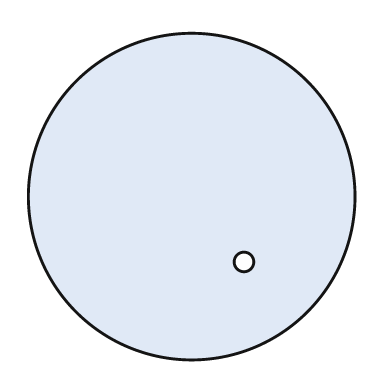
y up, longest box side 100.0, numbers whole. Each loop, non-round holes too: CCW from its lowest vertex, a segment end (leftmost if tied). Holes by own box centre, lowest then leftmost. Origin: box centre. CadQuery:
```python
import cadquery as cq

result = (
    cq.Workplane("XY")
    .moveTo(0.0, 0.0)
    .circle(50.0)
    .moveTo(16.0, -20.0)
    .circle(3.0)
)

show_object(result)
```